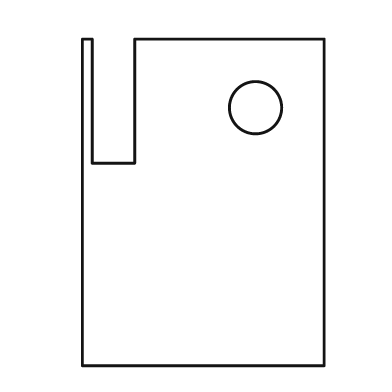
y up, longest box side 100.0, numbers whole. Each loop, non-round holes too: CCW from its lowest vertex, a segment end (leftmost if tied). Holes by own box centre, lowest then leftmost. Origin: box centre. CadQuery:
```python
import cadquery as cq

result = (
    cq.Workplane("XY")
    .moveTo(-37.0, -50.0)
    .lineTo(37.0, -50.0)
    .lineTo(37.0, 50.0)
    .lineTo(-21.0, 50.0)
    .lineTo(-21.0, 12.0)
    .lineTo(-34.0, 12.0)
    .lineTo(-34.0, 50.0)
    .lineTo(-37.0, 50.0)
    .close()
    .moveTo(16.0, 29.0)
    .circle(8.0)
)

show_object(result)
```